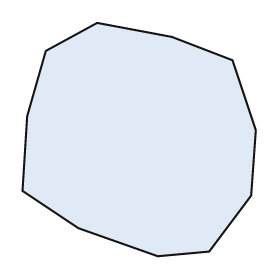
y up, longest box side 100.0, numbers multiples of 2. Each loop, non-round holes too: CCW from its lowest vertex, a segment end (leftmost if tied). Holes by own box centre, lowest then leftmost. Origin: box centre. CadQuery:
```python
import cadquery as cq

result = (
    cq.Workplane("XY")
    .moveTo(8.0, -50.0)
    .lineTo(30.0, -48.0)
    .lineTo(48.0, -24.0)
    .lineTo(50.0, 4.0)
    .lineTo(40.0, 34.0)
    .lineTo(14.0, 44.0)
    .lineTo(-18.0, 50.0)
    .lineTo(-40.0, 38.0)
    .lineTo(-48.0, 10.0)
    .lineTo(-50.0, -22.0)
    .lineTo(-26.0, -38.0)
    .close()
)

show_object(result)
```